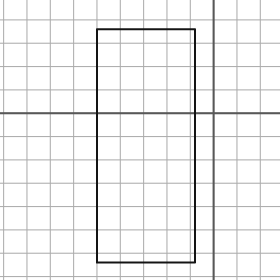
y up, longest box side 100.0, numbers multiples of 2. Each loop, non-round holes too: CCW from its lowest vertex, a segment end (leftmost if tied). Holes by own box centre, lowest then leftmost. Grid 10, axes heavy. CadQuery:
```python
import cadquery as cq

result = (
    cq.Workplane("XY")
    .moveTo(-50.0, -64.0)
    .lineTo(-8.0, -64.0)
    .lineTo(-8.0, 36.0)
    .lineTo(-50.0, 36.0)
    .close()
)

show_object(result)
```